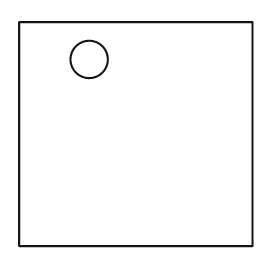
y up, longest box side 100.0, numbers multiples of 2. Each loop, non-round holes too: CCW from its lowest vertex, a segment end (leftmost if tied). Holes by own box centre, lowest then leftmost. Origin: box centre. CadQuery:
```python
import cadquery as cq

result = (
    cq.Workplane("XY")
    .moveTo(-50.0, -48.0)
    .lineTo(50.0, -48.0)
    .lineTo(50.0, 48.0)
    .lineTo(-50.0, 48.0)
    .close()
    .moveTo(-20.0, 32.0)
    .circle(8.0)
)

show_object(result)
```